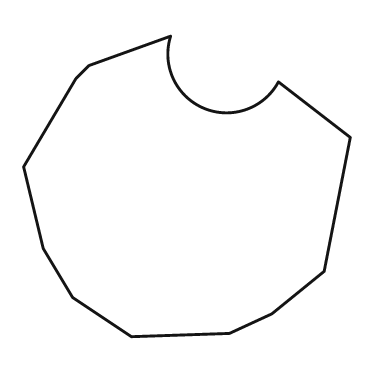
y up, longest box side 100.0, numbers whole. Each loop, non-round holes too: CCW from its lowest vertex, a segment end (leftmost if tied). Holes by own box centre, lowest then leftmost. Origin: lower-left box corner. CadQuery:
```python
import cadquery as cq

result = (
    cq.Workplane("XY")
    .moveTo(33.0, 0.0)
    .lineTo(63.0, 1.0)
    .lineTo(76.0, 7.0)
    .lineTo(92.0, 20.0)
    .lineTo(100.0, 61.0)
    .lineTo(78.0, 78.0)
    .threePointArc((55.0, 70.0), (45.0, 92.0))
    .lineTo(20.0, 83.0)
    .lineTo(16.0, 79.0)
    .lineTo(0.0, 52.0)
    .lineTo(6.0, 27.0)
    .lineTo(15.0, 12.0)
    .close()
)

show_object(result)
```